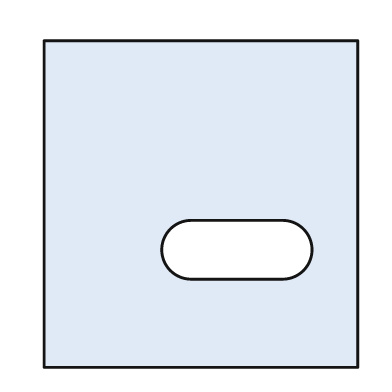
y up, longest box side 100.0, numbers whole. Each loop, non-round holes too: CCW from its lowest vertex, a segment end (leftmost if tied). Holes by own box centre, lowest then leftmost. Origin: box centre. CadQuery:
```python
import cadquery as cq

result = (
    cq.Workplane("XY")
    .moveTo(-48.0, -50.0)
    .lineTo(48.0, -50.0)
    .lineTo(48.0, 50.0)
    .lineTo(-48.0, 50.0)
    .close()
    .moveTo(-3.0, -23.0)
    .lineTo(25.0, -23.0)
    .threePointArc((34.0, -14.0), (25.0, -5.0))
    .lineTo(-3.0, -5.0)
    .threePointArc((-12.0, -14.0), (-3.0, -23.0))
    .close()
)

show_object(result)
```